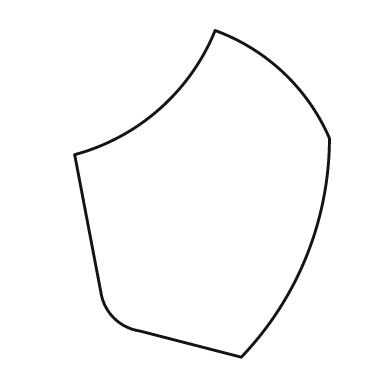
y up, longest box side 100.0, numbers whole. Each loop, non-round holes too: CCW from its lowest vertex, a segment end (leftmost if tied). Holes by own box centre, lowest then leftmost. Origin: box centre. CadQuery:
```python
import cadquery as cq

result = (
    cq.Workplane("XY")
    .moveTo(12.0, -50.0)
    .threePointArc((32.0, -19.0), (39.0, 17.0))
    .threePointArc((25.0, 37.0), (4.0, 50.0))
    .threePointArc((-13.0, 26.0), (-39.0, 12.0))
    .lineTo(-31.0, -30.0)
    .threePointArc((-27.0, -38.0), (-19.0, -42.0))
    .close()
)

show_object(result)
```